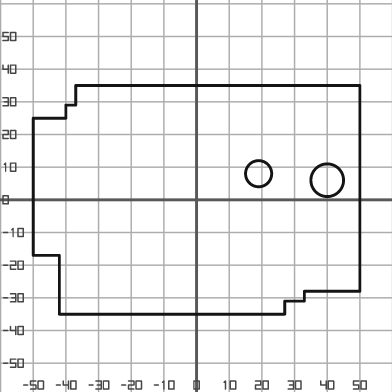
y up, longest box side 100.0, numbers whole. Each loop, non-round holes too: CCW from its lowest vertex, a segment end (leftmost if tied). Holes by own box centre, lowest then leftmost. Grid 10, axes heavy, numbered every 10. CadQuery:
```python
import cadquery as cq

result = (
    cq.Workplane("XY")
    .moveTo(-42.0, -35.0)
    .lineTo(27.0, -35.0)
    .lineTo(27.0, -31.0)
    .lineTo(33.0, -31.0)
    .lineTo(33.0, -28.0)
    .lineTo(50.0, -28.0)
    .lineTo(50.0, 35.0)
    .lineTo(-37.0, 35.0)
    .lineTo(-37.0, 29.0)
    .lineTo(-40.0, 29.0)
    .lineTo(-40.0, 25.0)
    .lineTo(-50.0, 25.0)
    .lineTo(-50.0, -17.0)
    .lineTo(-42.0, -17.0)
    .close()
    .moveTo(40.0, 6.0)
    .circle(5.0)
    .moveTo(19.0, 8.0)
    .circle(4.0)
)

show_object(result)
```